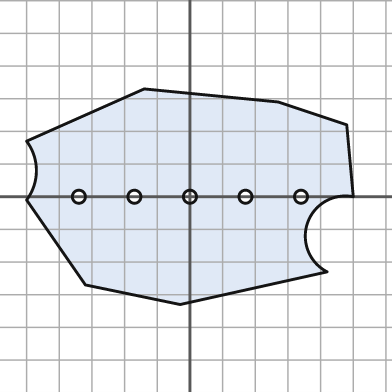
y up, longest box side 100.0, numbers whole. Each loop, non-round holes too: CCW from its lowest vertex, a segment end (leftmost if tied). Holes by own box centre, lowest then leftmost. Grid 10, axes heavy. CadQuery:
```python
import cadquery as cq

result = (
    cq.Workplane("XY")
    .moveTo(-3.0, -33.0)
    .lineTo(42.0, -23.0)
    .threePointArc((36.0, -8.0), (50.0, 0.0))
    .lineTo(48.0, 22.0)
    .lineTo(27.0, 29.0)
    .lineTo(-14.0, 33.0)
    .lineTo(-50.0, 17.0)
    .threePointArc((-47.0, 8.0), (-50.0, -1.0))
    .lineTo(-32.0, -27.0)
    .close()
    .moveTo(-34.0, 0.0)
    .circle(2.0)
    .moveTo(-17.0, 0.0)
    .circle(2.0)
    .moveTo(0.0, 0.0)
    .circle(2.0)
    .moveTo(17.0, 0.0)
    .circle(2.0)
    .moveTo(34.0, 0.0)
    .circle(2.0)
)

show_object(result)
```